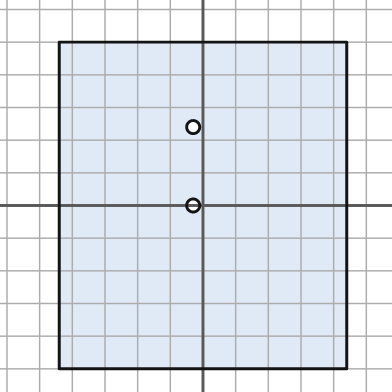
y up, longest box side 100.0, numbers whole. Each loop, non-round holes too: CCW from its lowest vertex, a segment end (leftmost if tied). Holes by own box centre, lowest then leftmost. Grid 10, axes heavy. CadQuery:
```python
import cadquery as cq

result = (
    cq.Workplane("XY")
    .moveTo(-44.0, -50.0)
    .lineTo(44.0, -50.0)
    .lineTo(44.0, 50.0)
    .lineTo(-44.0, 50.0)
    .close()
    .moveTo(-3.0, 0.0)
    .circle(2.0)
    .moveTo(-3.0, 24.0)
    .circle(2.0)
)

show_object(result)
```